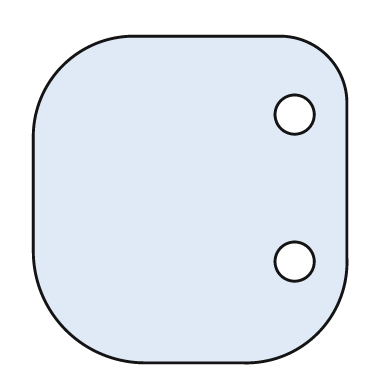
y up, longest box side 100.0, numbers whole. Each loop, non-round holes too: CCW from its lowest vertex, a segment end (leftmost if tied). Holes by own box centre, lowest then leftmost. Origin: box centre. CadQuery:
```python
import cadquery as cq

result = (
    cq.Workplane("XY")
    .moveTo(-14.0, -50.0)
    .lineTo(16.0, -50.0)
    .threePointArc((39.0, -41.0), (48.0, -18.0))
    .lineTo(48.0, 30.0)
    .threePointArc((42.0, 44.0), (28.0, 50.0))
    .lineTo(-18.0, 50.0)
    .threePointArc((-39.0, 41.0), (-48.0, 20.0))
    .lineTo(-48.0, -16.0)
    .threePointArc((-38.0, -40.0), (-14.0, -50.0))
    .close()
    .moveTo(32.0, -19.0)
    .circle(6.0)
    .moveTo(32.0, 26.0)
    .circle(6.0)
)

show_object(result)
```